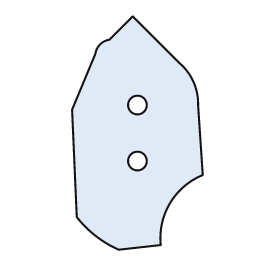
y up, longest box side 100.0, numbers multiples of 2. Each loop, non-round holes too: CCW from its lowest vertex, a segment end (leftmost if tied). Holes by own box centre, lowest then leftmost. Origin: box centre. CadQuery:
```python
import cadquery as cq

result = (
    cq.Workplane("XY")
    .moveTo(-8.0, -50.0)
    .lineTo(10.0, -48.0)
    .threePointArc((14.0, -30.0), (28.0, -18.0))
    .lineTo(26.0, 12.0)
    .threePointArc((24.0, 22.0), (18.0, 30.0))
    .lineTo(-2.0, 50.0)
    .lineTo(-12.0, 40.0)
    .threePointArc((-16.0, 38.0), (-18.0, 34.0))
    .lineTo(-28.0, 10.0)
    .lineTo(-26.0, -36.0)
    .threePointArc((-18.0, -44.0), (-8.0, -50.0))
    .close()
    .moveTo(0.0, -12.0)
    .circle(4.0)
    .moveTo(0.0, 12.0)
    .circle(4.0)
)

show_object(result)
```